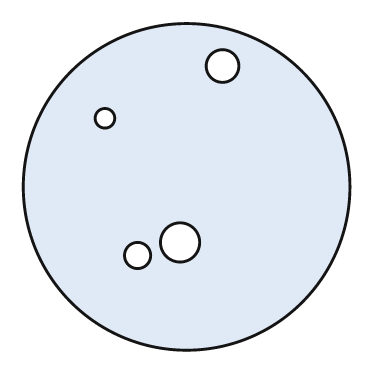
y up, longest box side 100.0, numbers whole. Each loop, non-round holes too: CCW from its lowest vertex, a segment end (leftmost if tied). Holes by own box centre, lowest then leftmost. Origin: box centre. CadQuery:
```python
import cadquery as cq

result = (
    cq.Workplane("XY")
    .moveTo(0.0, 0.0)
    .circle(50.0)
    .moveTo(-15.0, -21.0)
    .circle(4.0)
    .moveTo(-2.0, -17.0)
    .circle(6.0)
    .moveTo(-25.0, 21.0)
    .circle(3.0)
    .moveTo(11.0, 37.0)
    .circle(5.0)
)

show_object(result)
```